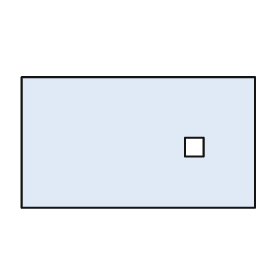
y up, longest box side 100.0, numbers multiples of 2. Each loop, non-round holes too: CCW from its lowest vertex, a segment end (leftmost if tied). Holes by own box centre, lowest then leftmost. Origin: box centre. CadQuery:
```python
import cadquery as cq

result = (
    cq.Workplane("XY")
    .moveTo(-50.0, -28.0)
    .lineTo(50.0, -28.0)
    .lineTo(50.0, 28.0)
    .lineTo(-50.0, 28.0)
    .close()
    .moveTo(20.0, -6.0)
    .lineTo(28.0, -6.0)
    .lineTo(28.0, 2.0)
    .lineTo(20.0, 2.0)
    .close()
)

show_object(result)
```